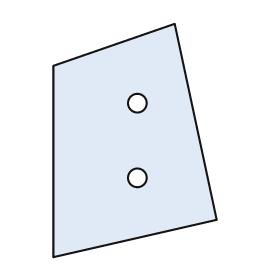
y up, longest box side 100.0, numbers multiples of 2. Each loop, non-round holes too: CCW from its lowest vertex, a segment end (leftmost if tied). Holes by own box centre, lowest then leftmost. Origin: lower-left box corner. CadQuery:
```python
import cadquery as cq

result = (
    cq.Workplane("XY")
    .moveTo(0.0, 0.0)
    .lineTo(70.0, 16.0)
    .lineTo(52.0, 100.0)
    .lineTo(0.0, 82.0)
    .close()
    .moveTo(36.0, 34.0)
    .circle(4.0)
    .moveTo(36.0, 66.0)
    .circle(4.0)
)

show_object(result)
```